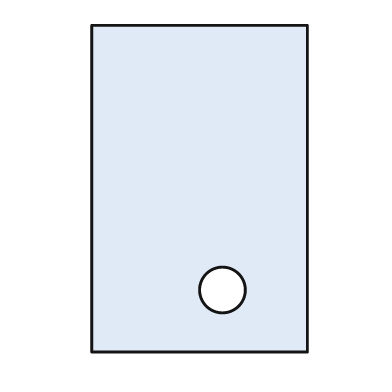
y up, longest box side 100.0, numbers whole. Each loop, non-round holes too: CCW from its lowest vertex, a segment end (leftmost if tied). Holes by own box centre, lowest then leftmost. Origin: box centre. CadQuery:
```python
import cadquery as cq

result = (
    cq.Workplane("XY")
    .moveTo(-33.0, -50.0)
    .lineTo(33.0, -50.0)
    .lineTo(33.0, 50.0)
    .lineTo(-33.0, 50.0)
    .close()
    .moveTo(7.0, -31.0)
    .circle(7.0)
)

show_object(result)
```